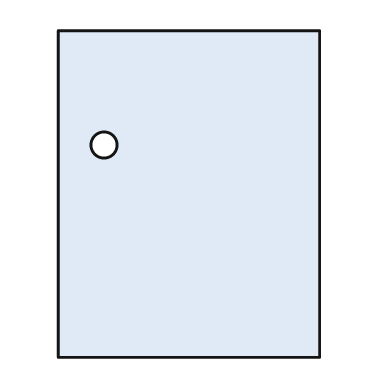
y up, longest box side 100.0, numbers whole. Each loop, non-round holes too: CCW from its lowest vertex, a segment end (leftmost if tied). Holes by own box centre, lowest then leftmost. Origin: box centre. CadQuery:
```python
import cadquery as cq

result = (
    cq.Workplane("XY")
    .moveTo(-40.0, -50.0)
    .lineTo(40.0, -50.0)
    .lineTo(40.0, 50.0)
    .lineTo(-40.0, 50.0)
    .close()
    .moveTo(-26.0, 15.0)
    .circle(4.0)
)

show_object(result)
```